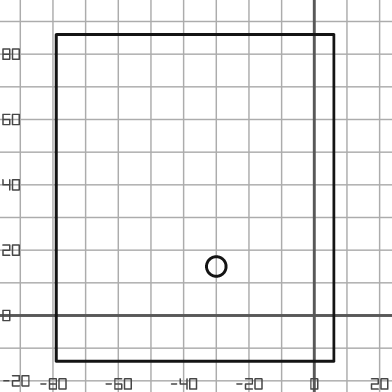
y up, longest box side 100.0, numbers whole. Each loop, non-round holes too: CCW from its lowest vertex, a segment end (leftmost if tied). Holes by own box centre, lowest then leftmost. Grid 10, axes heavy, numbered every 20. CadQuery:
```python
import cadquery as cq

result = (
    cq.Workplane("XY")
    .moveTo(-79.0, -14.0)
    .lineTo(6.0, -14.0)
    .lineTo(6.0, 86.0)
    .lineTo(-79.0, 86.0)
    .close()
    .moveTo(-30.0, 15.0)
    .circle(3.0)
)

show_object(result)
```